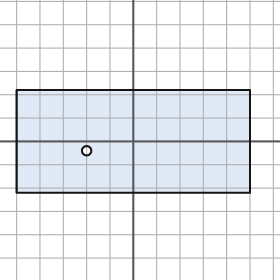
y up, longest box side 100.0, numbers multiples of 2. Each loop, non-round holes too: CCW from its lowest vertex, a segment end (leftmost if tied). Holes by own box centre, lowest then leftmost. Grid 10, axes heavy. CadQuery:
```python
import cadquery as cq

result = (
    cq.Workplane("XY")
    .moveTo(-50.0, -22.0)
    .lineTo(50.0, -22.0)
    .lineTo(50.0, 22.0)
    .lineTo(-50.0, 22.0)
    .close()
    .moveTo(-20.0, -4.0)
    .circle(2.0)
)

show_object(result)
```